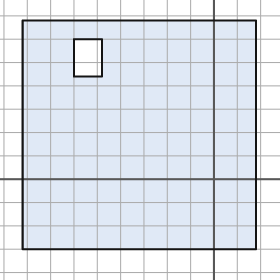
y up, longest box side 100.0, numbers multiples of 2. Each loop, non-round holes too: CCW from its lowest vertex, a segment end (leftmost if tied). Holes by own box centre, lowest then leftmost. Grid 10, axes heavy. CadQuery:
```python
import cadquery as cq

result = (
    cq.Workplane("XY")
    .moveTo(-82.0, -30.0)
    .lineTo(18.0, -30.0)
    .lineTo(18.0, 68.0)
    .lineTo(-82.0, 68.0)
    .close()
    .moveTo(-60.0, 44.0)
    .lineTo(-48.0, 44.0)
    .lineTo(-48.0, 60.0)
    .lineTo(-60.0, 60.0)
    .close()
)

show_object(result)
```